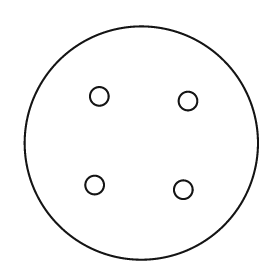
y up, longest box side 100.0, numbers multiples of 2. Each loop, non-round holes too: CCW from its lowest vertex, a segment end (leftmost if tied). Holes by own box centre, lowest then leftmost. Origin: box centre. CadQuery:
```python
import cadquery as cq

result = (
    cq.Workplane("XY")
    .moveTo(0.0, 0.0)
    .circle(50.0)
    .moveTo(18.0, -20.0)
    .circle(4.0)
    .moveTo(-20.0, -18.0)
    .circle(4.0)
    .moveTo(20.0, 18.0)
    .circle(4.0)
    .moveTo(-18.0, 20.0)
    .circle(4.0)
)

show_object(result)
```